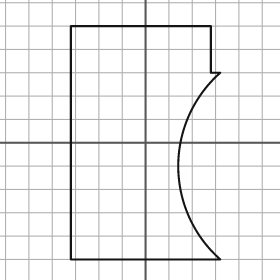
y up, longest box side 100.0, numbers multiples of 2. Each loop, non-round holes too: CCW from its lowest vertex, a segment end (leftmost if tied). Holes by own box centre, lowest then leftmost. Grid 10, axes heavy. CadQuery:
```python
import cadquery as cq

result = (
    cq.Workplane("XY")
    .moveTo(-32.0, -50.0)
    .lineTo(32.0, -50.0)
    .threePointArc((14.0, -10.0), (32.0, 30.0))
    .lineTo(28.0, 30.0)
    .lineTo(28.0, 50.0)
    .lineTo(-32.0, 50.0)
    .close()
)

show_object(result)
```